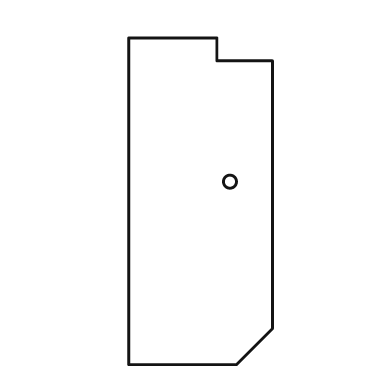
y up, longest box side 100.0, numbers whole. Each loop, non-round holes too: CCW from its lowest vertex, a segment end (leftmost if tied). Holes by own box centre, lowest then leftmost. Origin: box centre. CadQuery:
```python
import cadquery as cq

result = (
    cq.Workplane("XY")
    .moveTo(-22.0, -50.0)
    .lineTo(11.0, -50.0)
    .lineTo(22.0, -39.0)
    .lineTo(22.0, 43.0)
    .lineTo(5.0, 43.0)
    .lineTo(5.0, 50.0)
    .lineTo(-22.0, 50.0)
    .close()
    .moveTo(9.0, 6.0)
    .circle(2.0)
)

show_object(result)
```